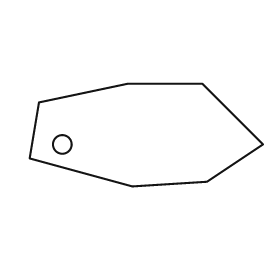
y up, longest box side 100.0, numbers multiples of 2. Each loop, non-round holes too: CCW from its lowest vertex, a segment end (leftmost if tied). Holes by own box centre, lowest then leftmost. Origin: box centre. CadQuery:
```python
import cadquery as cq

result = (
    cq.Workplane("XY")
    .moveTo(-6.0, -22.0)
    .lineTo(26.0, -20.0)
    .lineTo(50.0, -4.0)
    .lineTo(24.0, 22.0)
    .lineTo(-8.0, 22.0)
    .lineTo(-46.0, 14.0)
    .lineTo(-50.0, -10.0)
    .close()
    .moveTo(-36.0, -4.0)
    .circle(4.0)
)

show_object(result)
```